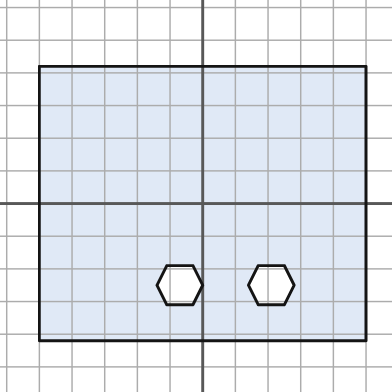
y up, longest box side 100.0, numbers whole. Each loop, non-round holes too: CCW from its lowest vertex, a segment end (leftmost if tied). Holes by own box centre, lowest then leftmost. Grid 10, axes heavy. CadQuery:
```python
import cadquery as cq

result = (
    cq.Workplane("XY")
    .moveTo(-50.0, -42.0)
    .lineTo(50.0, -42.0)
    .lineTo(50.0, 42.0)
    .lineTo(-50.0, 42.0)
    .close()
    .moveTo(-11.0, -31.0)
    .lineTo(-3.0, -31.0)
    .lineTo(0.0, -25.0)
    .lineTo(-3.0, -19.0)
    .lineTo(-11.0, -19.0)
    .lineTo(-14.0, -25.0)
    .close()
    .moveTo(17.0, -31.0)
    .lineTo(25.0, -31.0)
    .lineTo(28.0, -25.0)
    .lineTo(25.0, -19.0)
    .lineTo(17.0, -19.0)
    .lineTo(14.0, -25.0)
    .close()
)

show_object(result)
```